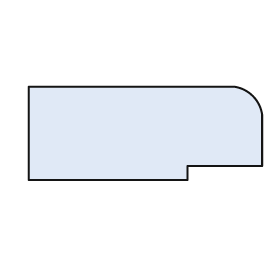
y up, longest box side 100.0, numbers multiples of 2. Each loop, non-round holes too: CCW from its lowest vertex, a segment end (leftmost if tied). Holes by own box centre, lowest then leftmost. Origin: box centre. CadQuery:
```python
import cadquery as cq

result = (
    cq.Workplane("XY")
    .moveTo(-50.0, -20.0)
    .lineTo(18.0, -20.0)
    .lineTo(18.0, -14.0)
    .lineTo(50.0, -14.0)
    .lineTo(50.0, 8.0)
    .threePointArc((46.0, 16.0), (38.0, 20.0))
    .lineTo(-50.0, 20.0)
    .close()
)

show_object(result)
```